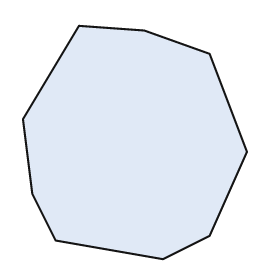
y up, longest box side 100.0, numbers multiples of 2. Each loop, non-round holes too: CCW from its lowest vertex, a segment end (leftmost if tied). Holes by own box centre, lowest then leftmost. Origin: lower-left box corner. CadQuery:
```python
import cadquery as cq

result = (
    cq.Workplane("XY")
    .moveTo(60.0, 0.0)
    .lineTo(80.0, 10.0)
    .lineTo(96.0, 46.0)
    .lineTo(80.0, 88.0)
    .lineTo(52.0, 98.0)
    .lineTo(24.0, 100.0)
    .lineTo(0.0, 60.0)
    .lineTo(4.0, 28.0)
    .lineTo(14.0, 8.0)
    .close()
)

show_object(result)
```